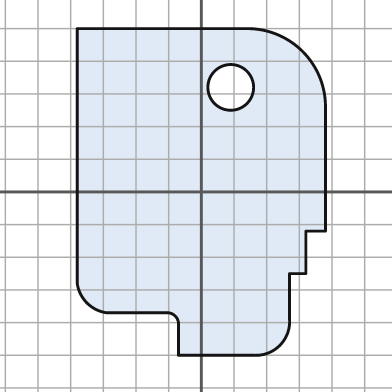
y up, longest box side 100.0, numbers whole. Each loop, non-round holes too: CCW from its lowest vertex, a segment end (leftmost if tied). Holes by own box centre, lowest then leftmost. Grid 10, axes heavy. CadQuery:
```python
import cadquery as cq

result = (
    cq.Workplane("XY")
    .moveTo(-7.0, -50.0)
    .lineTo(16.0, -50.0)
    .threePointArc((24.0, -47.0), (27.0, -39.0))
    .lineTo(27.0, -25.0)
    .lineTo(32.0, -25.0)
    .lineTo(32.0, -12.0)
    .lineTo(38.0, -12.0)
    .lineTo(38.0, 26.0)
    .threePointArc((31.0, 43.0), (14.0, 50.0))
    .lineTo(-38.0, 50.0)
    .lineTo(-38.0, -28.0)
    .threePointArc((-35.0, -34.0), (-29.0, -37.0))
    .lineTo(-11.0, -37.0)
    .threePointArc((-8.0, -38.0), (-7.0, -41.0))
    .close()
    .moveTo(9.0, 32.0)
    .circle(7.0)
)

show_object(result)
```